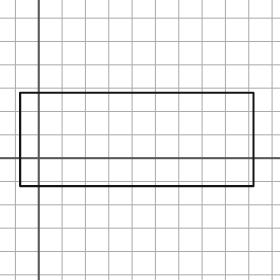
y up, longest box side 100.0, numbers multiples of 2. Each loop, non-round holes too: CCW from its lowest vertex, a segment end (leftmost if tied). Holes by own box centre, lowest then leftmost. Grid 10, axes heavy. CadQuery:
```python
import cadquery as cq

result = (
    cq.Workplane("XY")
    .moveTo(-8.0, -12.0)
    .lineTo(92.0, -12.0)
    .lineTo(92.0, 28.0)
    .lineTo(-8.0, 28.0)
    .close()
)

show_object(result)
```